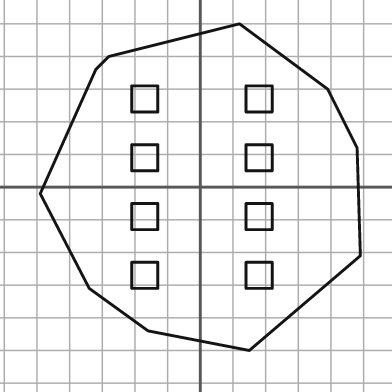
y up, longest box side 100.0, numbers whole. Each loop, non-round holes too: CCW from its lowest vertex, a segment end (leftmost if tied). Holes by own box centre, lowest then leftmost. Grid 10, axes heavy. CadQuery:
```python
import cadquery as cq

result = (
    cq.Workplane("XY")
    .moveTo(15.0, -50.0)
    .lineTo(49.0, -21.0)
    .lineTo(48.0, 12.0)
    .lineTo(39.0, 30.0)
    .lineTo(12.0, 50.0)
    .lineTo(-28.0, 40.0)
    .lineTo(-32.0, 36.0)
    .lineTo(-49.0, -2.0)
    .lineTo(-34.0, -31.0)
    .lineTo(-16.0, -44.0)
    .close()
    .moveTo(-21.0, -31.0)
    .lineTo(-13.0, -31.0)
    .lineTo(-13.0, -23.0)
    .lineTo(-21.0, -23.0)
    .close()
    .moveTo(14.0, -31.0)
    .lineTo(22.0, -31.0)
    .lineTo(22.0, -23.0)
    .lineTo(14.0, -23.0)
    .close()
    .moveTo(-21.0, -13.0)
    .lineTo(-13.0, -13.0)
    .lineTo(-13.0, -5.0)
    .lineTo(-21.0, -5.0)
    .close()
    .moveTo(14.0, -13.0)
    .lineTo(22.0, -13.0)
    .lineTo(22.0, -5.0)
    .lineTo(14.0, -5.0)
    .close()
    .moveTo(-21.0, 5.0)
    .lineTo(-13.0, 5.0)
    .lineTo(-13.0, 13.0)
    .lineTo(-21.0, 13.0)
    .close()
    .moveTo(14.0, 5.0)
    .lineTo(22.0, 5.0)
    .lineTo(22.0, 13.0)
    .lineTo(14.0, 13.0)
    .close()
    .moveTo(-21.0, 23.0)
    .lineTo(-13.0, 23.0)
    .lineTo(-13.0, 31.0)
    .lineTo(-21.0, 31.0)
    .close()
    .moveTo(14.0, 23.0)
    .lineTo(22.0, 23.0)
    .lineTo(22.0, 31.0)
    .lineTo(14.0, 31.0)
    .close()
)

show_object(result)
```